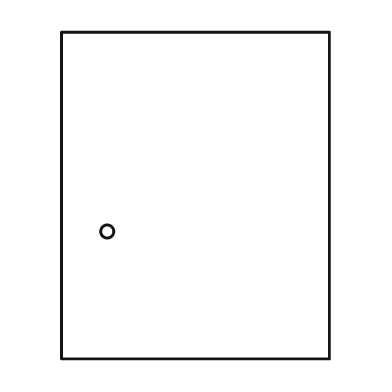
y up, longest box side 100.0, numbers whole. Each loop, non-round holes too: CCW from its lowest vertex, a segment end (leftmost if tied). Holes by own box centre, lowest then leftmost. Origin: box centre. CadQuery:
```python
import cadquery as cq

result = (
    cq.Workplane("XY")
    .moveTo(-41.0, -50.0)
    .lineTo(41.0, -50.0)
    .lineTo(41.0, 50.0)
    .lineTo(-41.0, 50.0)
    .close()
    .moveTo(-27.0, -11.0)
    .circle(2.0)
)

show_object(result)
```